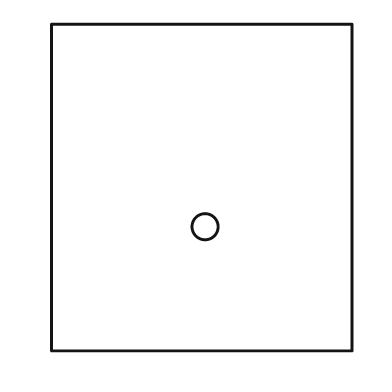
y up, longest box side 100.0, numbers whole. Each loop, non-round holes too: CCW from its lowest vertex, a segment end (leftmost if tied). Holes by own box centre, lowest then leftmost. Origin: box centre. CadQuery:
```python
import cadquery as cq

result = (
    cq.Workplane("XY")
    .moveTo(-46.0, -50.0)
    .lineTo(46.0, -50.0)
    .lineTo(46.0, 50.0)
    .lineTo(-46.0, 50.0)
    .close()
    .moveTo(1.0, -12.0)
    .circle(4.0)
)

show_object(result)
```